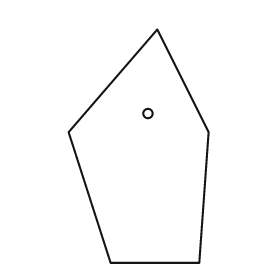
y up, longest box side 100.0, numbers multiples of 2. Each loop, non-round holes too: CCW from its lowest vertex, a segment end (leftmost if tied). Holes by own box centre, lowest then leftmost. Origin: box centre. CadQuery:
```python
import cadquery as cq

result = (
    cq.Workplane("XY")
    .moveTo(-12.0, -50.0)
    .lineTo(26.0, -50.0)
    .lineTo(30.0, 6.0)
    .lineTo(8.0, 50.0)
    .lineTo(-30.0, 6.0)
    .close()
    .moveTo(4.0, 14.0)
    .circle(2.0)
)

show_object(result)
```